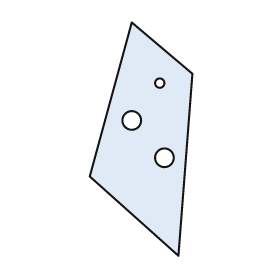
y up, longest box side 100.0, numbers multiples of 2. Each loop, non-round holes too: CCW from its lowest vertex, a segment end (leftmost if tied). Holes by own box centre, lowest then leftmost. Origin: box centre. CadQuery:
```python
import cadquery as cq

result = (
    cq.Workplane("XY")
    .moveTo(16.0, -50.0)
    .lineTo(22.0, 28.0)
    .lineTo(-4.0, 50.0)
    .lineTo(-22.0, -16.0)
    .close()
    .moveTo(10.0, -8.0)
    .circle(4.0)
    .moveTo(-4.0, 8.0)
    .circle(4.0)
    .moveTo(8.0, 24.0)
    .circle(2.0)
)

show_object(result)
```